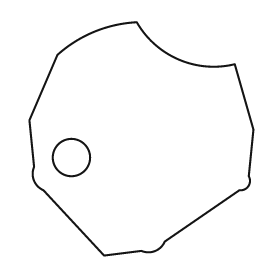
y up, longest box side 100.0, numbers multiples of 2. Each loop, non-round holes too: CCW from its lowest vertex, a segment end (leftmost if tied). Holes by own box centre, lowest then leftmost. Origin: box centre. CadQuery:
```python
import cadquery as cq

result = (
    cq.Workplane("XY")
    .moveTo(-16.0, -50.0)
    .lineTo(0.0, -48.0)
    .threePointArc((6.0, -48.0), (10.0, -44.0))
    .lineTo(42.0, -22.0)
    .threePointArc((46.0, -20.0), (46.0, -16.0))
    .lineTo(48.0, 4.0)
    .lineTo(40.0, 32.0)
    .threePointArc((16.0, 34.0), (-2.0, 50.0))
    .threePointArc((-20.0, 46.0), (-36.0, 36.0))
    .lineTo(-48.0, 8.0)
    .lineTo(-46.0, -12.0)
    .threePointArc((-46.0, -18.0), (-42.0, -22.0))
    .close()
    .moveTo(-30.0, -8.0)
    .circle(8.0)
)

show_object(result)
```